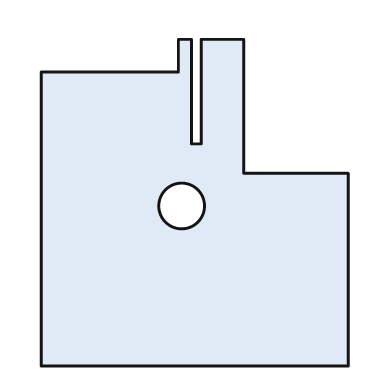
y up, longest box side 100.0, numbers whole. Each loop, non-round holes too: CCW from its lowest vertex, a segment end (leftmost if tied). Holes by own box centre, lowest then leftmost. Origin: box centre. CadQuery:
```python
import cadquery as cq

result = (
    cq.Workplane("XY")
    .moveTo(-47.0, -50.0)
    .lineTo(47.0, -50.0)
    .lineTo(47.0, 9.0)
    .lineTo(15.0, 9.0)
    .lineTo(15.0, 50.0)
    .lineTo(2.0, 50.0)
    .lineTo(2.0, 18.0)
    .lineTo(-1.0, 18.0)
    .lineTo(-1.0, 50.0)
    .lineTo(-5.0, 50.0)
    .lineTo(-5.0, 40.0)
    .lineTo(-47.0, 40.0)
    .close()
    .moveTo(-4.0, -1.0)
    .circle(7.0)
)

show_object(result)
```